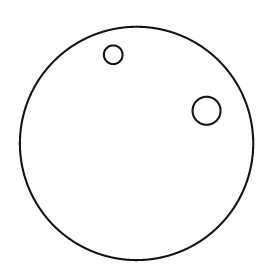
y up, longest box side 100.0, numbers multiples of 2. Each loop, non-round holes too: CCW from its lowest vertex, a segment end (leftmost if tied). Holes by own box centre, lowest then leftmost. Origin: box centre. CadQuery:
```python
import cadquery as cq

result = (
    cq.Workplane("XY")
    .moveTo(0.0, 0.0)
    .circle(50.0)
    .moveTo(30.0, 14.0)
    .circle(6.0)
    .moveTo(-10.0, 38.0)
    .circle(4.0)
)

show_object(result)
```